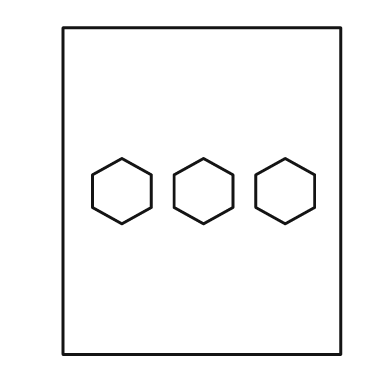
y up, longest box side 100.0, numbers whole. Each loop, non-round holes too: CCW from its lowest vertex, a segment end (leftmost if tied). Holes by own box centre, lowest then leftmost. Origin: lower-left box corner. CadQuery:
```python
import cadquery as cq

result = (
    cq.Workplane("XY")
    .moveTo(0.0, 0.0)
    .lineTo(85.0, 0.0)
    .lineTo(85.0, 100.0)
    .lineTo(0.0, 100.0)
    .close()
    .moveTo(18.0, 40.0)
    .lineTo(27.0, 45.0)
    .lineTo(27.0, 55.0)
    .lineTo(18.0, 60.0)
    .lineTo(9.0, 55.0)
    .lineTo(9.0, 45.0)
    .close()
    .moveTo(43.0, 40.0)
    .lineTo(52.0, 45.0)
    .lineTo(52.0, 55.0)
    .lineTo(43.0, 60.0)
    .lineTo(34.0, 55.0)
    .lineTo(34.0, 45.0)
    .close()
    .moveTo(68.0, 40.0)
    .lineTo(77.0, 45.0)
    .lineTo(77.0, 55.0)
    .lineTo(68.0, 60.0)
    .lineTo(59.0, 55.0)
    .lineTo(59.0, 45.0)
    .close()
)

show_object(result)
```